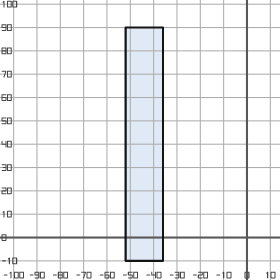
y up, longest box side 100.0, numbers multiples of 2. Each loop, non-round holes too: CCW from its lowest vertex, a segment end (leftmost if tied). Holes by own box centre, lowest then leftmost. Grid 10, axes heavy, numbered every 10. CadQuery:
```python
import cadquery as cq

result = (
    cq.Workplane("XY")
    .moveTo(-52.0, -10.0)
    .lineTo(-36.0, -10.0)
    .lineTo(-36.0, 90.0)
    .lineTo(-52.0, 90.0)
    .close()
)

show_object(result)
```